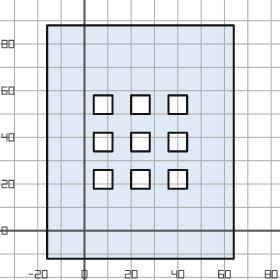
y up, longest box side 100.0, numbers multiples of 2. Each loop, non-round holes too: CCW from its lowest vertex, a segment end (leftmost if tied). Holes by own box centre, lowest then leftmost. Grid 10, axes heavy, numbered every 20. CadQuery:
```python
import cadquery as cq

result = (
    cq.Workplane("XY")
    .moveTo(-16.0, -12.0)
    .lineTo(64.0, -12.0)
    .lineTo(64.0, 88.0)
    .lineTo(-16.0, 88.0)
    .close()
    .moveTo(4.0, 18.0)
    .lineTo(12.0, 18.0)
    .lineTo(12.0, 26.0)
    .lineTo(4.0, 26.0)
    .close()
    .moveTo(20.0, 18.0)
    .lineTo(28.0, 18.0)
    .lineTo(28.0, 26.0)
    .lineTo(20.0, 26.0)
    .close()
    .moveTo(36.0, 18.0)
    .lineTo(44.0, 18.0)
    .lineTo(44.0, 26.0)
    .lineTo(36.0, 26.0)
    .close()
    .moveTo(4.0, 34.0)
    .lineTo(12.0, 34.0)
    .lineTo(12.0, 42.0)
    .lineTo(4.0, 42.0)
    .close()
    .moveTo(20.0, 34.0)
    .lineTo(28.0, 34.0)
    .lineTo(28.0, 42.0)
    .lineTo(20.0, 42.0)
    .close()
    .moveTo(36.0, 34.0)
    .lineTo(44.0, 34.0)
    .lineTo(44.0, 42.0)
    .lineTo(36.0, 42.0)
    .close()
    .moveTo(4.0, 50.0)
    .lineTo(12.0, 50.0)
    .lineTo(12.0, 58.0)
    .lineTo(4.0, 58.0)
    .close()
    .moveTo(20.0, 50.0)
    .lineTo(28.0, 50.0)
    .lineTo(28.0, 58.0)
    .lineTo(20.0, 58.0)
    .close()
    .moveTo(36.0, 50.0)
    .lineTo(44.0, 50.0)
    .lineTo(44.0, 58.0)
    .lineTo(36.0, 58.0)
    .close()
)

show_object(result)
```